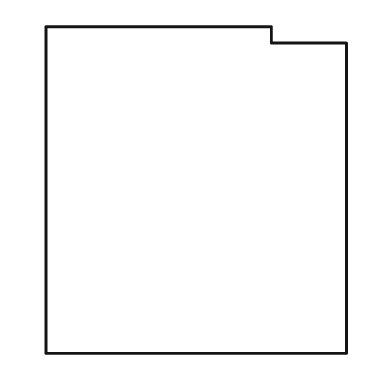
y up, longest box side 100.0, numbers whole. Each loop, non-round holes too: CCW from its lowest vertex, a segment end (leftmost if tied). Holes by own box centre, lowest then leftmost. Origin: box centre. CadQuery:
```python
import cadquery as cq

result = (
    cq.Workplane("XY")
    .moveTo(-46.0, -50.0)
    .lineTo(46.0, -50.0)
    .lineTo(46.0, 45.0)
    .lineTo(23.0, 45.0)
    .lineTo(23.0, 50.0)
    .lineTo(-46.0, 50.0)
    .close()
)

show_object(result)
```